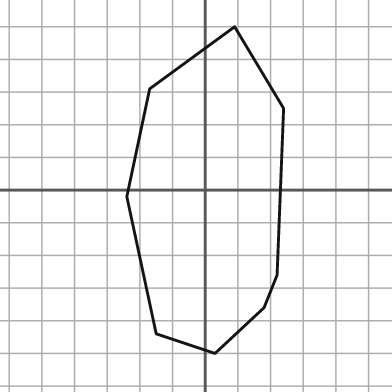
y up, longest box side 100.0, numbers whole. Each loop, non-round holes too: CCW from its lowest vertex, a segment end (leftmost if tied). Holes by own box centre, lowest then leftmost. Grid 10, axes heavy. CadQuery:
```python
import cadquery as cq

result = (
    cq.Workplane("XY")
    .moveTo(3.0, -50.0)
    .lineTo(18.0, -36.0)
    .lineTo(22.0, -26.0)
    .lineTo(24.0, 25.0)
    .lineTo(9.0, 50.0)
    .lineTo(-17.0, 31.0)
    .lineTo(-24.0, -2.0)
    .lineTo(-15.0, -44.0)
    .close()
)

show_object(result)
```